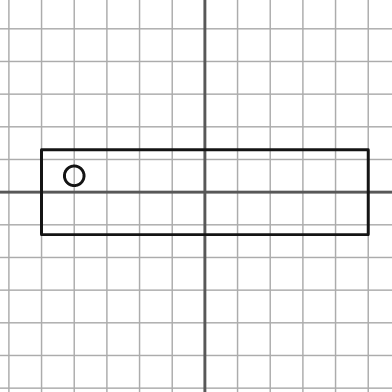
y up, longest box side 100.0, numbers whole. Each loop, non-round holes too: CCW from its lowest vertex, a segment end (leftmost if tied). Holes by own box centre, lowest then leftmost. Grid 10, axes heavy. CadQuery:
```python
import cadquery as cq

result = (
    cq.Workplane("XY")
    .moveTo(-50.0, -13.0)
    .lineTo(50.0, -13.0)
    .lineTo(50.0, 13.0)
    .lineTo(-50.0, 13.0)
    .close()
    .moveTo(-40.0, 5.0)
    .circle(3.0)
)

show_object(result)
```